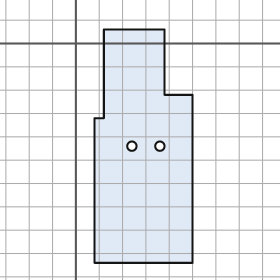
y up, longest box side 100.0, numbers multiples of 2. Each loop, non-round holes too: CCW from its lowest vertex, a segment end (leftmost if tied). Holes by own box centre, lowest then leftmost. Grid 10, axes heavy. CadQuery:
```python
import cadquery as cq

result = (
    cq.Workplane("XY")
    .moveTo(8.0, -94.0)
    .lineTo(50.0, -94.0)
    .lineTo(50.0, -22.0)
    .lineTo(38.0, -22.0)
    .lineTo(38.0, 6.0)
    .lineTo(12.0, 6.0)
    .lineTo(12.0, -32.0)
    .lineTo(8.0, -32.0)
    .close()
    .moveTo(24.0, -44.0)
    .circle(2.0)
    .moveTo(36.0, -44.0)
    .circle(2.0)
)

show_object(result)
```